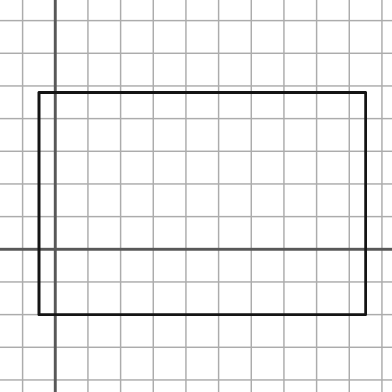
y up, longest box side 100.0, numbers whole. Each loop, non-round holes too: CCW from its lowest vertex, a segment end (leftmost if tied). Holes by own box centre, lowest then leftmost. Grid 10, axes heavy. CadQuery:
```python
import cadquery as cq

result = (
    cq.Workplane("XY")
    .moveTo(-5.0, -20.0)
    .lineTo(95.0, -20.0)
    .lineTo(95.0, 48.0)
    .lineTo(-5.0, 48.0)
    .close()
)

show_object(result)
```